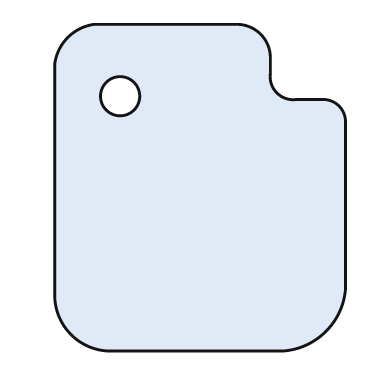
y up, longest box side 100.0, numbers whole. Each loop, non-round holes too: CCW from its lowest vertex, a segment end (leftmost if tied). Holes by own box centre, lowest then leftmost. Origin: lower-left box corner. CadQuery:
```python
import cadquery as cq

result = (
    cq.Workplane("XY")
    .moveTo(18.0, 0.0)
    .lineTo(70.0, 0.0)
    .threePointArc((83.0, 6.0), (89.0, 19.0))
    .lineTo(89.0, 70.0)
    .threePointArc((87.0, 75.0), (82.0, 77.0))
    .lineTo(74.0, 77.0)
    .threePointArc((68.0, 79.0), (66.0, 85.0))
    .lineTo(66.0, 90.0)
    .threePointArc((63.0, 97.0), (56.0, 100.0))
    .lineTo(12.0, 100.0)
    .threePointArc((4.0, 96.0), (0.0, 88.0))
    .lineTo(0.0, 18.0)
    .threePointArc((5.0, 5.0), (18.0, 0.0))
    .close()
    .moveTo(20.0, 78.0)
    .circle(6.0)
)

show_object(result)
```